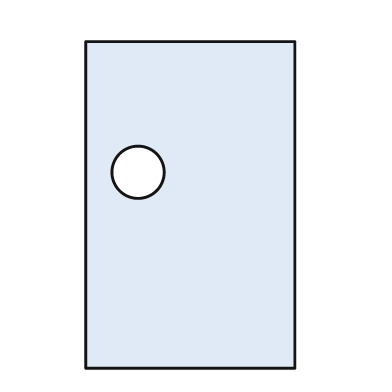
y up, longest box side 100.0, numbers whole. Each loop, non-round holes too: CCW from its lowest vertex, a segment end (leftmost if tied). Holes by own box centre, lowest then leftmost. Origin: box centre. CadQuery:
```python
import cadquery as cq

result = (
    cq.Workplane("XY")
    .moveTo(-32.0, -50.0)
    .lineTo(32.0, -50.0)
    .lineTo(32.0, 50.0)
    .lineTo(-32.0, 50.0)
    .close()
    .moveTo(-16.0, 10.0)
    .circle(8.0)
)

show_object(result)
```